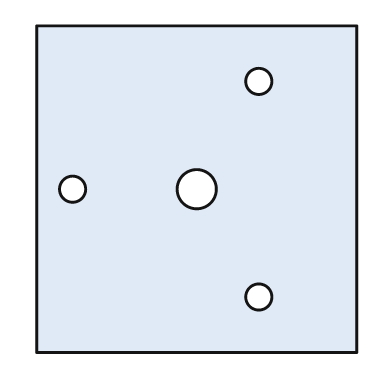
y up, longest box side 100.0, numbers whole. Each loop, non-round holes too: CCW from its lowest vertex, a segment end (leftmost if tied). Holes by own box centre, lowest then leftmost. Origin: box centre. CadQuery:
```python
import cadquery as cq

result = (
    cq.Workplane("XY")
    .moveTo(-49.0, -50.0)
    .lineTo(49.0, -50.0)
    .lineTo(49.0, 50.0)
    .lineTo(-49.0, 50.0)
    .close()
    .moveTo(19.0, -33.0)
    .circle(4.0)
    .moveTo(-38.0, 0.0)
    .circle(4.0)
    .moveTo(0.0, 0.0)
    .circle(6.0)
    .moveTo(19.0, 33.0)
    .circle(4.0)
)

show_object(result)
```